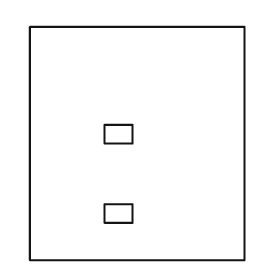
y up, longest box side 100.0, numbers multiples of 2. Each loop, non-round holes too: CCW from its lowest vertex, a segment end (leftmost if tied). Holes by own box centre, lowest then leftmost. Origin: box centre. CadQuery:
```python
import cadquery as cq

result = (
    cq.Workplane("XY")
    .moveTo(-46.0, -50.0)
    .lineTo(46.0, -50.0)
    .lineTo(46.0, 50.0)
    .lineTo(-46.0, 50.0)
    .close()
    .moveTo(-14.0, -34.0)
    .lineTo(-2.0, -34.0)
    .lineTo(-2.0, -26.0)
    .lineTo(-14.0, -26.0)
    .close()
    .moveTo(-14.0, 0.0)
    .lineTo(-2.0, 0.0)
    .lineTo(-2.0, 8.0)
    .lineTo(-14.0, 8.0)
    .close()
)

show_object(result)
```